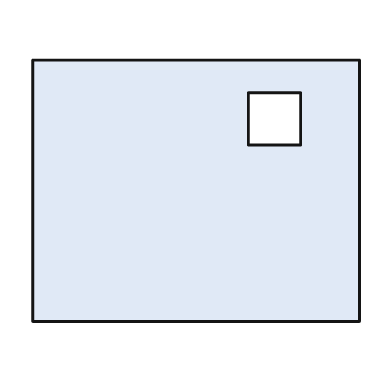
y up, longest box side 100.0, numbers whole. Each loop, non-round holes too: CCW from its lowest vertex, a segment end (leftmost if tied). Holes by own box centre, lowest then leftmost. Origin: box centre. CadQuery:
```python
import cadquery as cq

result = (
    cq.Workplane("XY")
    .moveTo(-50.0, -40.0)
    .lineTo(50.0, -40.0)
    .lineTo(50.0, 40.0)
    .lineTo(-50.0, 40.0)
    .close()
    .moveTo(16.0, 14.0)
    .lineTo(32.0, 14.0)
    .lineTo(32.0, 30.0)
    .lineTo(16.0, 30.0)
    .close()
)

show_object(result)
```